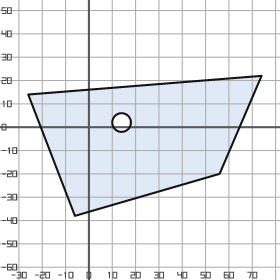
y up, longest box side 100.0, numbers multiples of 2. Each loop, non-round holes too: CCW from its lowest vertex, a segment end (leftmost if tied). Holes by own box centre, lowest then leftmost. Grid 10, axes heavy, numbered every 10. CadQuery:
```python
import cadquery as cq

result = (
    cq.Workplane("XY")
    .moveTo(-6.0, -38.0)
    .lineTo(56.0, -20.0)
    .lineTo(74.0, 22.0)
    .lineTo(-26.0, 14.0)
    .close()
    .moveTo(14.0, 2.0)
    .circle(4.0)
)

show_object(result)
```